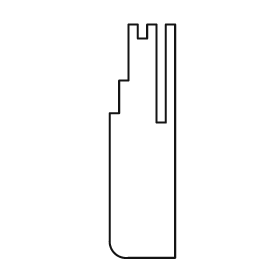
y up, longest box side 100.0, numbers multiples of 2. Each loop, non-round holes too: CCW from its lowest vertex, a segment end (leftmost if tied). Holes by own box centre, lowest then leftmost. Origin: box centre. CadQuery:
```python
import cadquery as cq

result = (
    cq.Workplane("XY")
    .moveTo(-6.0, -50.0)
    .lineTo(14.0, -50.0)
    .lineTo(14.0, 50.0)
    .lineTo(10.0, 50.0)
    .lineTo(10.0, 8.0)
    .lineTo(6.0, 8.0)
    .lineTo(6.0, 50.0)
    .lineTo(2.0, 50.0)
    .lineTo(2.0, 44.0)
    .lineTo(-2.0, 44.0)
    .lineTo(-2.0, 50.0)
    .lineTo(-6.0, 50.0)
    .lineTo(-6.0, 26.0)
    .lineTo(-10.0, 26.0)
    .lineTo(-10.0, 12.0)
    .lineTo(-14.0, 12.0)
    .lineTo(-14.0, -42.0)
    .threePointArc((-12.0, -48.0), (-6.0, -50.0))
    .close()
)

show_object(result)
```